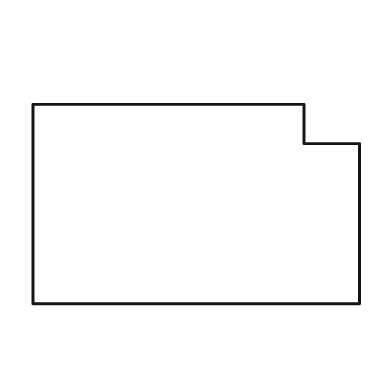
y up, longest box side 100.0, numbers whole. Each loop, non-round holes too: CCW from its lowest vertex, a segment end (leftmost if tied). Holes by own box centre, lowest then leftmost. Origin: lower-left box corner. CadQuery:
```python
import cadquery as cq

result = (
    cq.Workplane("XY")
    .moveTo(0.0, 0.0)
    .lineTo(100.0, 0.0)
    .lineTo(100.0, 49.0)
    .lineTo(83.0, 49.0)
    .lineTo(83.0, 61.0)
    .lineTo(0.0, 61.0)
    .close()
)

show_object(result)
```